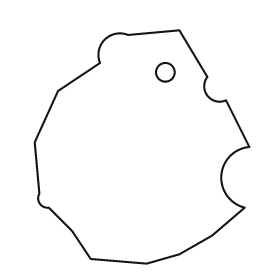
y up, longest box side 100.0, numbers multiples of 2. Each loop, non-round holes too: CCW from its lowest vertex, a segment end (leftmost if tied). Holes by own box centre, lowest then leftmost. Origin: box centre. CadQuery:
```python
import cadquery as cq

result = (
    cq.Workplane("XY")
    .moveTo(2.0, -50.0)
    .lineTo(16.0, -46.0)
    .lineTo(30.0, -38.0)
    .lineTo(44.0, -26.0)
    .threePointArc((34.0, -12.0), (46.0, 0.0))
    .lineTo(36.0, 20.0)
    .threePointArc((28.0, 22.0), (28.0, 30.0))
    .lineTo(16.0, 50.0)
    .lineTo(-6.0, 48.0)
    .threePointArc((-16.0, 46.0), (-18.0, 36.0))
    .lineTo(-36.0, 24.0)
    .lineTo(-46.0, 2.0)
    .lineTo(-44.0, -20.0)
    .threePointArc((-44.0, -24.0), (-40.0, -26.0))
    .lineTo(-30.0, -36.0)
    .lineTo(-22.0, -48.0)
    .close()
    .moveTo(10.0, 32.0)
    .circle(4.0)
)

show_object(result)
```